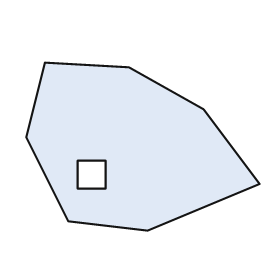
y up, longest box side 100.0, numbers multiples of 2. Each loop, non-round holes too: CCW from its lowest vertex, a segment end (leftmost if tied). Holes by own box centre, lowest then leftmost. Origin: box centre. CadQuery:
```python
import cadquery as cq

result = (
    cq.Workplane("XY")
    .moveTo(2.0, -36.0)
    .lineTo(50.0, -16.0)
    .lineTo(26.0, 16.0)
    .lineTo(-6.0, 34.0)
    .lineTo(-42.0, 36.0)
    .lineTo(-50.0, 4.0)
    .lineTo(-32.0, -32.0)
    .close()
    .moveTo(-28.0, -18.0)
    .lineTo(-16.0, -18.0)
    .lineTo(-16.0, -6.0)
    .lineTo(-28.0, -6.0)
    .close()
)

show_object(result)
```